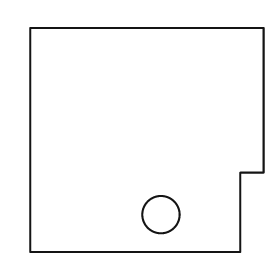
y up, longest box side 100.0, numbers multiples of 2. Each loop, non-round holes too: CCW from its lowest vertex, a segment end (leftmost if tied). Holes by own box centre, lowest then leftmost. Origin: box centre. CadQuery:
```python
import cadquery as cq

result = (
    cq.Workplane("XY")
    .moveTo(-50.0, -48.0)
    .lineTo(40.0, -48.0)
    .lineTo(40.0, -14.0)
    .lineTo(50.0, -14.0)
    .lineTo(50.0, 48.0)
    .lineTo(-50.0, 48.0)
    .close()
    .moveTo(6.0, -32.0)
    .circle(8.0)
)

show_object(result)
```